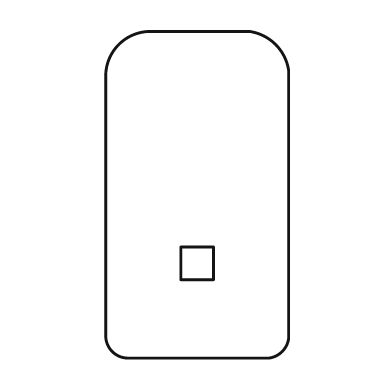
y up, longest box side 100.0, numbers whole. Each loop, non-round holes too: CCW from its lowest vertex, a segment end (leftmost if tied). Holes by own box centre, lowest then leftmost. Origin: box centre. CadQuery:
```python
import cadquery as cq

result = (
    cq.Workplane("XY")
    .moveTo(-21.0, -50.0)
    .lineTo(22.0, -50.0)
    .threePointArc((26.0, -48.0), (28.0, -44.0))
    .lineTo(28.0, 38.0)
    .threePointArc((24.0, 46.0), (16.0, 50.0))
    .lineTo(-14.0, 50.0)
    .threePointArc((-24.0, 46.0), (-28.0, 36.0))
    .lineTo(-28.0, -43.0)
    .threePointArc((-26.0, -48.0), (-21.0, -50.0))
    .close()
    .moveTo(-5.0, -26.0)
    .lineTo(5.0, -26.0)
    .lineTo(5.0, -16.0)
    .lineTo(-5.0, -16.0)
    .close()
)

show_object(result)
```